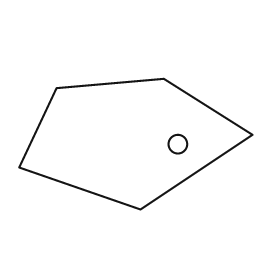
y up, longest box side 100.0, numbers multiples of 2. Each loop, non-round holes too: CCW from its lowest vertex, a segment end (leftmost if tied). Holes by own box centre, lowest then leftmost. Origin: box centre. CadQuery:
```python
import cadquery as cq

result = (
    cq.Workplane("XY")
    .moveTo(2.0, -28.0)
    .lineTo(50.0, 4.0)
    .lineTo(12.0, 28.0)
    .lineTo(-34.0, 24.0)
    .lineTo(-50.0, -10.0)
    .close()
    .moveTo(18.0, 0.0)
    .circle(4.0)
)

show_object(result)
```